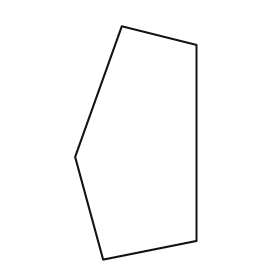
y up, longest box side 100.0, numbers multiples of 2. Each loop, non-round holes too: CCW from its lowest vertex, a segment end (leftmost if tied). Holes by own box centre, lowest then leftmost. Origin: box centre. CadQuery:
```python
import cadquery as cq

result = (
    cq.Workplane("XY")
    .moveTo(-14.0, -50.0)
    .lineTo(26.0, -42.0)
    .lineTo(26.0, 42.0)
    .lineTo(-6.0, 50.0)
    .lineTo(-26.0, -6.0)
    .close()
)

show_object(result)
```